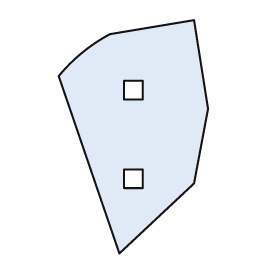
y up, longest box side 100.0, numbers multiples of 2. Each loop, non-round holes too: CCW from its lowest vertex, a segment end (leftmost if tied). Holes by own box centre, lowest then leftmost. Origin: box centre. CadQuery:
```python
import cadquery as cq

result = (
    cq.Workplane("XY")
    .moveTo(-6.0, -50.0)
    .lineTo(26.0, -20.0)
    .lineTo(32.0, 12.0)
    .lineTo(26.0, 50.0)
    .lineTo(-10.0, 44.0)
    .threePointArc((-22.0, 36.0), (-32.0, 26.0))
    .close()
    .moveTo(-4.0, -22.0)
    .lineTo(4.0, -22.0)
    .lineTo(4.0, -14.0)
    .lineTo(-4.0, -14.0)
    .close()
    .moveTo(-4.0, 16.0)
    .lineTo(4.0, 16.0)
    .lineTo(4.0, 24.0)
    .lineTo(-4.0, 24.0)
    .close()
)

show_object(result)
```